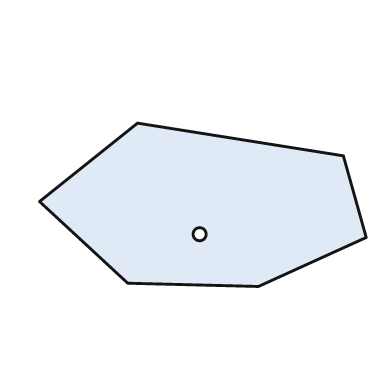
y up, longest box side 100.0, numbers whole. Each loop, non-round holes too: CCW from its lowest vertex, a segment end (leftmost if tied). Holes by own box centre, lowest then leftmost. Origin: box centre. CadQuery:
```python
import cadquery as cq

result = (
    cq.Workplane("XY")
    .moveTo(17.0, -25.0)
    .lineTo(50.0, -10.0)
    .lineTo(43.0, 15.0)
    .lineTo(-20.0, 25.0)
    .lineTo(-50.0, 1.0)
    .lineTo(-23.0, -24.0)
    .close()
    .moveTo(-1.0, -9.0)
    .circle(2.0)
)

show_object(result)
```